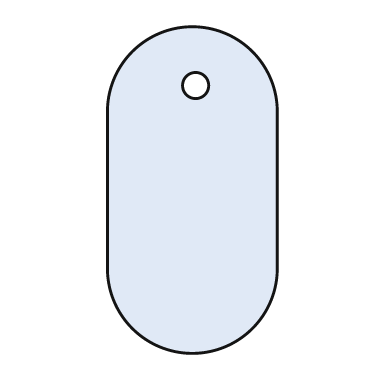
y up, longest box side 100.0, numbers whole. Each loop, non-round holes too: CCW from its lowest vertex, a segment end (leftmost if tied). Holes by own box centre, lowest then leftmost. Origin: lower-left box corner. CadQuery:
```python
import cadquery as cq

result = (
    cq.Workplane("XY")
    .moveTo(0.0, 26.0)
    .threePointArc((26.0, 0.0), (52.0, 26.0))
    .lineTo(52.0, 74.0)
    .threePointArc((26.0, 100.0), (0.0, 74.0))
    .close()
    .moveTo(27.0, 82.0)
    .circle(4.0)
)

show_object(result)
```